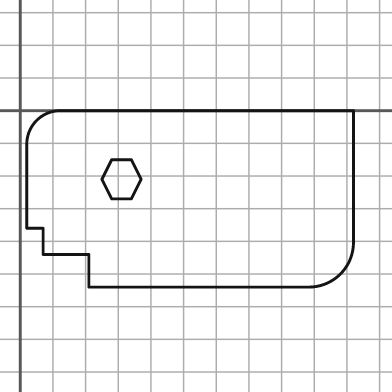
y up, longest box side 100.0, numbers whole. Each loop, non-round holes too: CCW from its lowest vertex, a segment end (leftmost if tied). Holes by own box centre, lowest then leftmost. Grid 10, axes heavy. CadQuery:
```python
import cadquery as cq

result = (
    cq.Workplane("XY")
    .moveTo(21.0, -54.0)
    .lineTo(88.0, -54.0)
    .threePointArc((98.0, -50.0), (102.0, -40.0))
    .lineTo(102.0, 0.0)
    .lineTo(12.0, 0.0)
    .threePointArc((5.0, -3.0), (2.0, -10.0))
    .lineTo(2.0, -36.0)
    .lineTo(7.0, -36.0)
    .lineTo(7.0, -44.0)
    .lineTo(21.0, -44.0)
    .close()
    .moveTo(28.0, -27.0)
    .lineTo(34.0, -27.0)
    .lineTo(37.0, -21.0)
    .lineTo(34.0, -15.0)
    .lineTo(28.0, -15.0)
    .lineTo(25.0, -21.0)
    .close()
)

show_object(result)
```